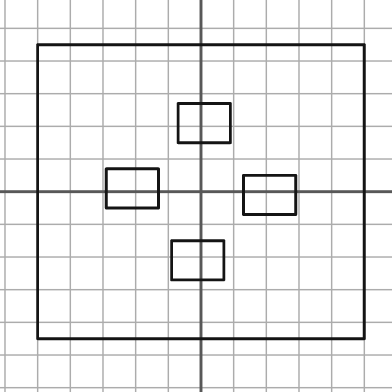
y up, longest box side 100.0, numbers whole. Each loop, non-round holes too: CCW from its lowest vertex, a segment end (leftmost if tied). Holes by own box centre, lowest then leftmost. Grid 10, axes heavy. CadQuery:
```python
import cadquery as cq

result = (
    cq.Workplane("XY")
    .moveTo(-50.0, -45.0)
    .lineTo(50.0, -45.0)
    .lineTo(50.0, 45.0)
    .lineTo(-50.0, 45.0)
    .close()
    .moveTo(-9.0, -27.0)
    .lineTo(7.0, -27.0)
    .lineTo(7.0, -15.0)
    .lineTo(-9.0, -15.0)
    .close()
    .moveTo(13.0, -7.0)
    .lineTo(29.0, -7.0)
    .lineTo(29.0, 5.0)
    .lineTo(13.0, 5.0)
    .close()
    .moveTo(-29.0, -5.0)
    .lineTo(-13.0, -5.0)
    .lineTo(-13.0, 7.0)
    .lineTo(-29.0, 7.0)
    .close()
    .moveTo(-7.0, 15.0)
    .lineTo(9.0, 15.0)
    .lineTo(9.0, 27.0)
    .lineTo(-7.0, 27.0)
    .close()
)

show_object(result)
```